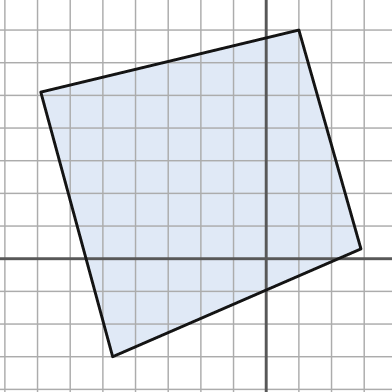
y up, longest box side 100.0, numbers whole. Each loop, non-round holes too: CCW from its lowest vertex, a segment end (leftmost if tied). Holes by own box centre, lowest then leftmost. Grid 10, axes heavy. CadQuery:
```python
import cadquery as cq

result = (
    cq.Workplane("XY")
    .moveTo(-47.0, -30.0)
    .lineTo(29.0, 3.0)
    .lineTo(10.0, 70.0)
    .lineTo(-69.0, 51.0)
    .close()
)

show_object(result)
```